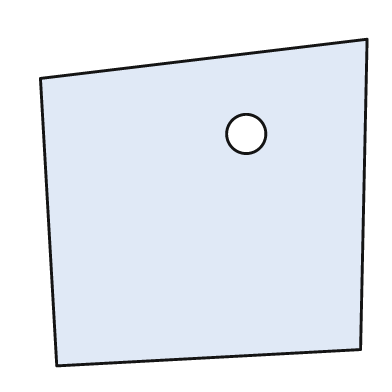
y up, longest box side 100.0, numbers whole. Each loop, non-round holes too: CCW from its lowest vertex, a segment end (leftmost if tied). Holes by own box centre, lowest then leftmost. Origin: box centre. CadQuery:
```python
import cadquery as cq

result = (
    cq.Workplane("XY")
    .moveTo(-45.0, -50.0)
    .lineTo(48.0, -45.0)
    .lineTo(50.0, 50.0)
    .lineTo(-50.0, 38.0)
    .close()
    .moveTo(13.0, 21.0)
    .circle(6.0)
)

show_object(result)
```